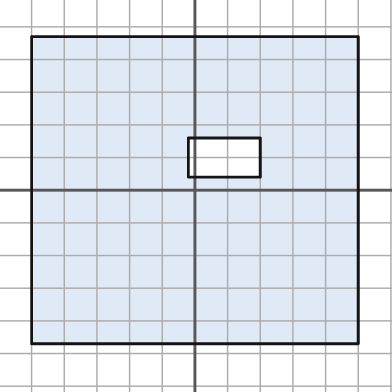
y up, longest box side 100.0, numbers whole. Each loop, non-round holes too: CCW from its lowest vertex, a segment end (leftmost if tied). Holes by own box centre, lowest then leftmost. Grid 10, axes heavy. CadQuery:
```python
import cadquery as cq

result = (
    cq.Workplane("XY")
    .moveTo(-50.0, -47.0)
    .lineTo(50.0, -47.0)
    .lineTo(50.0, 47.0)
    .lineTo(-50.0, 47.0)
    .close()
    .moveTo(-2.0, 4.0)
    .lineTo(20.0, 4.0)
    .lineTo(20.0, 16.0)
    .lineTo(-2.0, 16.0)
    .close()
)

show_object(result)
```